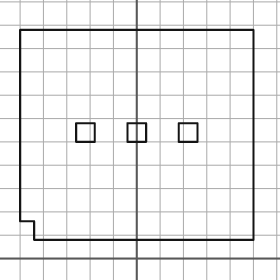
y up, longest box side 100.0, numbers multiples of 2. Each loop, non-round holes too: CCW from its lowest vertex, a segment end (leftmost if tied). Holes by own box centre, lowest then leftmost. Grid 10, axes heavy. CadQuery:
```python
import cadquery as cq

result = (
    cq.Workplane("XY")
    .moveTo(-44.0, 8.0)
    .lineTo(50.0, 8.0)
    .lineTo(50.0, 98.0)
    .lineTo(-50.0, 98.0)
    .lineTo(-50.0, 16.0)
    .lineTo(-44.0, 16.0)
    .close()
    .moveTo(-26.0, 50.0)
    .lineTo(-18.0, 50.0)
    .lineTo(-18.0, 58.0)
    .lineTo(-26.0, 58.0)
    .close()
    .moveTo(-4.0, 50.0)
    .lineTo(4.0, 50.0)
    .lineTo(4.0, 58.0)
    .lineTo(-4.0, 58.0)
    .close()
    .moveTo(18.0, 50.0)
    .lineTo(26.0, 50.0)
    .lineTo(26.0, 58.0)
    .lineTo(18.0, 58.0)
    .close()
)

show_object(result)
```